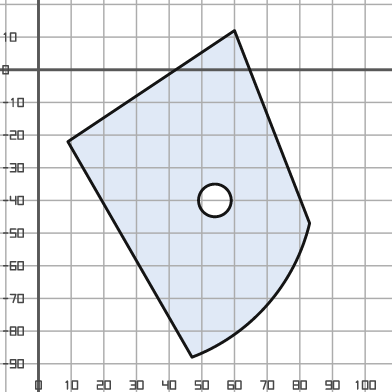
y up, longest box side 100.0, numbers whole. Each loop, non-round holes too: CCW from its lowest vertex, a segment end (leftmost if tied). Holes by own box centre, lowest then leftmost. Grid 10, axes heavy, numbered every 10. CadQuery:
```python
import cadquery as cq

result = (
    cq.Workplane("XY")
    .moveTo(47.0, -88.0)
    .threePointArc((70.0, -72.0), (83.0, -47.0))
    .lineTo(60.0, 12.0)
    .lineTo(9.0, -22.0)
    .close()
    .moveTo(54.0, -40.0)
    .circle(5.0)
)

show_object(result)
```